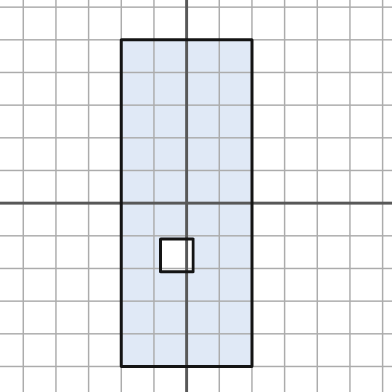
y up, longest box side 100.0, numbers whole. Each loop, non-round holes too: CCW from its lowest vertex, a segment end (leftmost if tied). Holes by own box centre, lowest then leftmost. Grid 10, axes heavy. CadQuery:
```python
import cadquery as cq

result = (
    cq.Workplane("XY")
    .moveTo(-20.0, -50.0)
    .lineTo(20.0, -50.0)
    .lineTo(20.0, 50.0)
    .lineTo(-20.0, 50.0)
    .close()
    .moveTo(-8.0, -21.0)
    .lineTo(2.0, -21.0)
    .lineTo(2.0, -11.0)
    .lineTo(-8.0, -11.0)
    .close()
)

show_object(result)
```